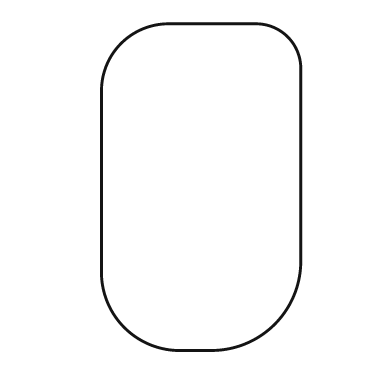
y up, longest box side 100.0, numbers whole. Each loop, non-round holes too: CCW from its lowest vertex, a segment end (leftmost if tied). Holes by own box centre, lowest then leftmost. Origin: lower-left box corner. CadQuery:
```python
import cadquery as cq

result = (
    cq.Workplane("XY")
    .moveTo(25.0, 0.0)
    .lineTo(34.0, 0.0)
    .threePointArc((53.0, 8.0), (61.0, 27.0))
    .lineTo(61.0, 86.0)
    .threePointArc((57.0, 96.0), (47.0, 100.0))
    .lineTo(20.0, 100.0)
    .threePointArc((6.0, 94.0), (0.0, 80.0))
    .lineTo(0.0, 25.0)
    .threePointArc((7.0, 7.0), (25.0, 0.0))
    .close()
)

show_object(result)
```